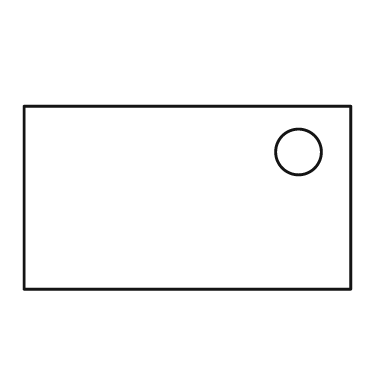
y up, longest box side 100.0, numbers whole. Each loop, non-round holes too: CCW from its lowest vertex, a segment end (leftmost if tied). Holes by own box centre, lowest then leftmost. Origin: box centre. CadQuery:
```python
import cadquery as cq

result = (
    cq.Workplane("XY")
    .moveTo(-50.0, -28.0)
    .lineTo(50.0, -28.0)
    .lineTo(50.0, 28.0)
    .lineTo(-50.0, 28.0)
    .close()
    .moveTo(34.0, 14.0)
    .circle(7.0)
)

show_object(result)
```